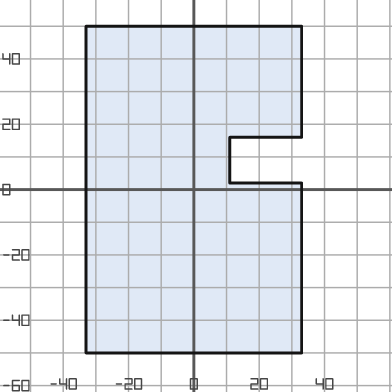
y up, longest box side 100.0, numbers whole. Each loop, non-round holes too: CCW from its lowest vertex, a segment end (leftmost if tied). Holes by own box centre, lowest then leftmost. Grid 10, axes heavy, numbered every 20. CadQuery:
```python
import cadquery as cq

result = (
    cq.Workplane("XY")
    .moveTo(-33.0, -50.0)
    .lineTo(33.0, -50.0)
    .lineTo(33.0, 2.0)
    .lineTo(11.0, 2.0)
    .lineTo(11.0, 16.0)
    .lineTo(33.0, 16.0)
    .lineTo(33.0, 50.0)
    .lineTo(-33.0, 50.0)
    .close()
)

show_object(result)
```